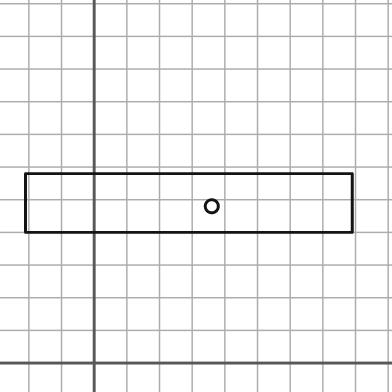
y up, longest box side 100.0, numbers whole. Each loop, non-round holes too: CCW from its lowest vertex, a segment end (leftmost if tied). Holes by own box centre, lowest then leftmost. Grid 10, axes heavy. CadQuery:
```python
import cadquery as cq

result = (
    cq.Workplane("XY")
    .moveTo(-21.0, 40.0)
    .lineTo(79.0, 40.0)
    .lineTo(79.0, 58.0)
    .lineTo(-21.0, 58.0)
    .close()
    .moveTo(36.0, 48.0)
    .circle(2.0)
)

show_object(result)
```